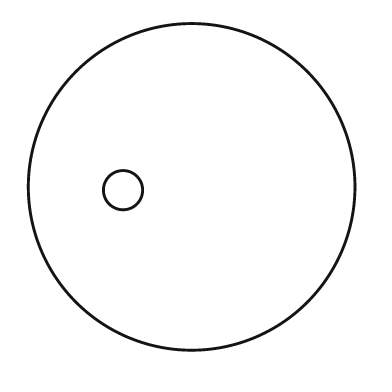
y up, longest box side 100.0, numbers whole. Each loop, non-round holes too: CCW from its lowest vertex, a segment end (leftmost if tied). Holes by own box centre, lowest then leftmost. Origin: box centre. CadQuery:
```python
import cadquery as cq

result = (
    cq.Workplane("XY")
    .moveTo(0.0, 0.0)
    .circle(50.0)
    .moveTo(-21.0, -1.0)
    .circle(6.0)
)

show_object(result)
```